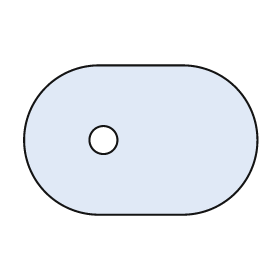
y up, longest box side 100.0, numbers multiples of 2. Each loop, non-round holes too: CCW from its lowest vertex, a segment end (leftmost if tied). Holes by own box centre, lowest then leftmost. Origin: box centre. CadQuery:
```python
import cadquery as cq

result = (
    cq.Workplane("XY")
    .moveTo(-18.0, -32.0)
    .lineTo(18.0, -32.0)
    .threePointArc((50.0, 0.0), (18.0, 32.0))
    .lineTo(-18.0, 32.0)
    .threePointArc((-50.0, 0.0), (-18.0, -32.0))
    .close()
    .moveTo(-16.0, 0.0)
    .circle(6.0)
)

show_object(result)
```